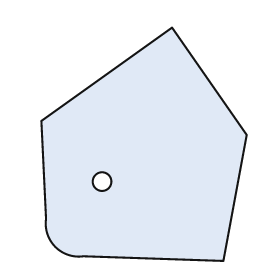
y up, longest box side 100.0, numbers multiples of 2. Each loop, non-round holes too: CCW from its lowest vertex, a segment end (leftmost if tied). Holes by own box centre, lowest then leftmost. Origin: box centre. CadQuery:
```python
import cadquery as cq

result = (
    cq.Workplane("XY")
    .moveTo(34.0, -50.0)
    .lineTo(44.0, 4.0)
    .lineTo(12.0, 50.0)
    .lineTo(-44.0, 10.0)
    .lineTo(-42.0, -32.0)
    .threePointArc((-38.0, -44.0), (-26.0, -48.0))
    .close()
    .moveTo(-18.0, -16.0)
    .circle(4.0)
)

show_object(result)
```